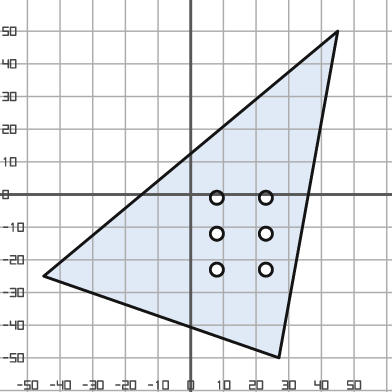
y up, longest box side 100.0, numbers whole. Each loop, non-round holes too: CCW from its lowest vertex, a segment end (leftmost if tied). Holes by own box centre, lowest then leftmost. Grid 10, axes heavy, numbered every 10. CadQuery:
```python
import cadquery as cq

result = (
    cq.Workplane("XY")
    .moveTo(27.0, -50.0)
    .lineTo(45.0, 50.0)
    .lineTo(-45.0, -25.0)
    .close()
    .moveTo(8.0, -23.0)
    .circle(2.0)
    .moveTo(23.0, -23.0)
    .circle(2.0)
    .moveTo(8.0, -12.0)
    .circle(2.0)
    .moveTo(23.0, -12.0)
    .circle(2.0)
    .moveTo(8.0, -1.0)
    .circle(2.0)
    .moveTo(23.0, -1.0)
    .circle(2.0)
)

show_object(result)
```